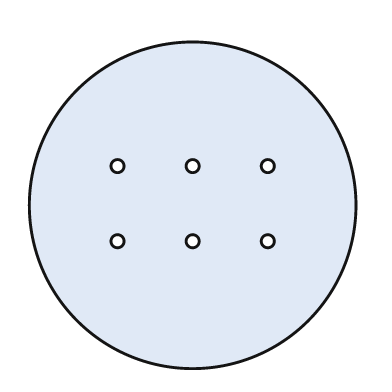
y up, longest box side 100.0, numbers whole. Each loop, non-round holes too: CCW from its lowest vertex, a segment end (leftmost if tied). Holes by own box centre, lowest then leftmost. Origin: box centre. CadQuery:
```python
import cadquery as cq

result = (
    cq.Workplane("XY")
    .moveTo(0.0, 0.0)
    .circle(50.0)
    .moveTo(-23.0, -11.0)
    .circle(2.0)
    .moveTo(0.0, -11.0)
    .circle(2.0)
    .moveTo(23.0, -11.0)
    .circle(2.0)
    .moveTo(-23.0, 12.0)
    .circle(2.0)
    .moveTo(0.0, 12.0)
    .circle(2.0)
    .moveTo(23.0, 12.0)
    .circle(2.0)
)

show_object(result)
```